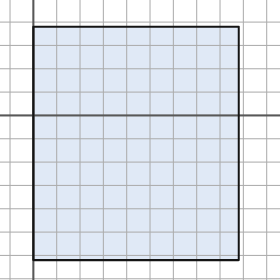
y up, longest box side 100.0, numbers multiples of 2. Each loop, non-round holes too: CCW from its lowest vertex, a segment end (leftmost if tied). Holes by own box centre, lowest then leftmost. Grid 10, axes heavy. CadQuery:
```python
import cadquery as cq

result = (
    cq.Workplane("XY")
    .moveTo(0.0, -62.0)
    .lineTo(88.0, -62.0)
    .lineTo(88.0, 38.0)
    .lineTo(0.0, 38.0)
    .close()
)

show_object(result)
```